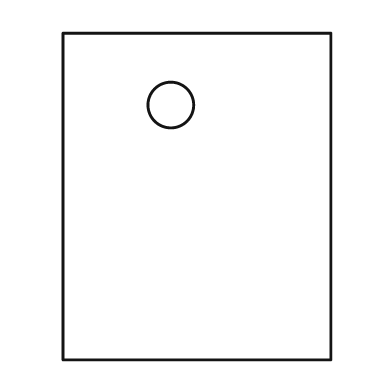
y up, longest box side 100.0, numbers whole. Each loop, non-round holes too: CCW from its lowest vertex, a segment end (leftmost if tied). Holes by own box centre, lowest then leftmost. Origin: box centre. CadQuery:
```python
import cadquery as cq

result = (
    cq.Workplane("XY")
    .moveTo(-41.0, -50.0)
    .lineTo(41.0, -50.0)
    .lineTo(41.0, 50.0)
    .lineTo(-41.0, 50.0)
    .close()
    .moveTo(-8.0, 28.0)
    .circle(7.0)
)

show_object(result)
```